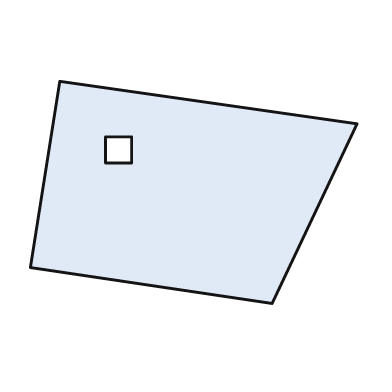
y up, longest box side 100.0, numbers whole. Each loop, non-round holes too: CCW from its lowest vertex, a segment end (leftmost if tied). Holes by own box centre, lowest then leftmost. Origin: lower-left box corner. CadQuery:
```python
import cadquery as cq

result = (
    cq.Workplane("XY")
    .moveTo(74.0, 0.0)
    .lineTo(100.0, 55.0)
    .lineTo(9.0, 68.0)
    .lineTo(0.0, 11.0)
    .close()
    .moveTo(23.0, 43.0)
    .lineTo(31.0, 43.0)
    .lineTo(31.0, 51.0)
    .lineTo(23.0, 51.0)
    .close()
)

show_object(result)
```